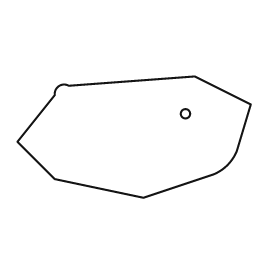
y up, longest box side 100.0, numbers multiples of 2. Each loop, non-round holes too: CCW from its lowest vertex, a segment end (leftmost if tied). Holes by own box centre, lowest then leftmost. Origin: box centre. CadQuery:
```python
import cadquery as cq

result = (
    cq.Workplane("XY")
    .moveTo(4.0, -26.0)
    .lineTo(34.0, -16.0)
    .threePointArc((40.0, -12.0), (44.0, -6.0))
    .lineTo(50.0, 14.0)
    .lineTo(26.0, 26.0)
    .lineTo(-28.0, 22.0)
    .threePointArc((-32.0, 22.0), (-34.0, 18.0))
    .lineTo(-50.0, -2.0)
    .lineTo(-34.0, -18.0)
    .close()
    .moveTo(22.0, 10.0)
    .circle(2.0)
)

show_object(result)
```